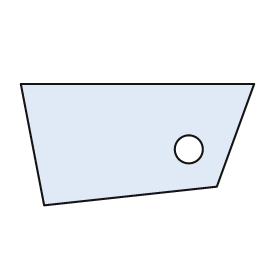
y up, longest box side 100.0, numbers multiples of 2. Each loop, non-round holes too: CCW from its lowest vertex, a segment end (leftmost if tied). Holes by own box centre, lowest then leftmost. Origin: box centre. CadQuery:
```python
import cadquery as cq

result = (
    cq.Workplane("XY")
    .moveTo(-40.0, -26.0)
    .lineTo(34.0, -18.0)
    .lineTo(50.0, 26.0)
    .lineTo(-50.0, 26.0)
    .close()
    .moveTo(22.0, -2.0)
    .circle(6.0)
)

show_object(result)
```